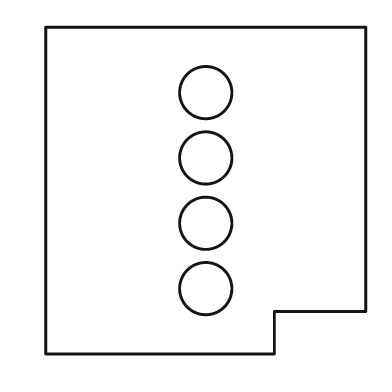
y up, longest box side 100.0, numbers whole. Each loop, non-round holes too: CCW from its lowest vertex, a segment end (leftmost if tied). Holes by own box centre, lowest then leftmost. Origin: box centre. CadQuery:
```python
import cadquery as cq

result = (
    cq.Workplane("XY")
    .moveTo(-49.0, -50.0)
    .lineTo(21.0, -50.0)
    .lineTo(21.0, -37.0)
    .lineTo(49.0, -37.0)
    .lineTo(49.0, 50.0)
    .lineTo(-49.0, 50.0)
    .close()
    .moveTo(0.0, -30.0)
    .circle(8.0)
    .moveTo(0.0, -10.0)
    .circle(8.0)
    .moveTo(0.0, 10.0)
    .circle(8.0)
    .moveTo(0.0, 30.0)
    .circle(8.0)
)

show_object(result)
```